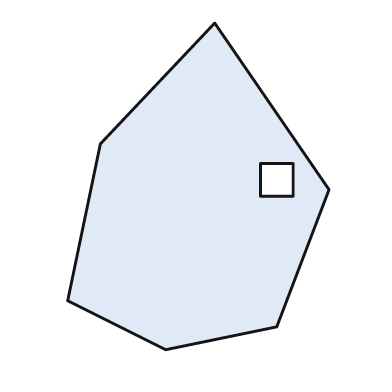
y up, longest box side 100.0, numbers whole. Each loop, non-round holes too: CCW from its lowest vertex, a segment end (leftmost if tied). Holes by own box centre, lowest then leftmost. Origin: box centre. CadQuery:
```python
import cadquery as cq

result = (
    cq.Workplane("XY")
    .moveTo(-10.0, -50.0)
    .lineTo(24.0, -43.0)
    .lineTo(40.0, -1.0)
    .lineTo(5.0, 50.0)
    .lineTo(-30.0, 13.0)
    .lineTo(-40.0, -35.0)
    .close()
    .moveTo(19.0, -3.0)
    .lineTo(29.0, -3.0)
    .lineTo(29.0, 7.0)
    .lineTo(19.0, 7.0)
    .close()
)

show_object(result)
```